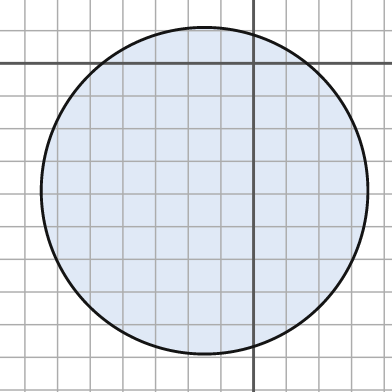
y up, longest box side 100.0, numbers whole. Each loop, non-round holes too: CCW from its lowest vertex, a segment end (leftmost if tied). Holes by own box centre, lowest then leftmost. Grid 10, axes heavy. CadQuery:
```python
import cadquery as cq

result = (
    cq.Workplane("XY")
    .moveTo(-15.0, -39.0)
    .circle(50.0)
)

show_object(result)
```